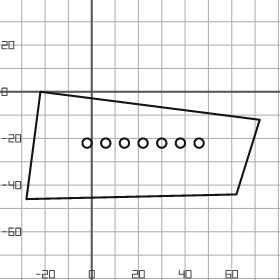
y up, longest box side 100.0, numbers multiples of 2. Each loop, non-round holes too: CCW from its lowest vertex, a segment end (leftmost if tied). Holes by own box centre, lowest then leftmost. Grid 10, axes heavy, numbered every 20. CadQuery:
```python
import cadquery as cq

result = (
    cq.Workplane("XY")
    .moveTo(-28.0, -46.0)
    .lineTo(62.0, -44.0)
    .lineTo(72.0, -12.0)
    .lineTo(-22.0, 0.0)
    .close()
    .moveTo(-2.0, -22.0)
    .circle(2.0)
    .moveTo(6.0, -22.0)
    .circle(2.0)
    .moveTo(14.0, -22.0)
    .circle(2.0)
    .moveTo(22.0, -22.0)
    .circle(2.0)
    .moveTo(30.0, -22.0)
    .circle(2.0)
    .moveTo(38.0, -22.0)
    .circle(2.0)
    .moveTo(46.0, -22.0)
    .circle(2.0)
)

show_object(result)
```